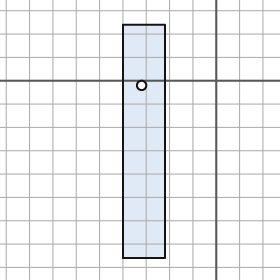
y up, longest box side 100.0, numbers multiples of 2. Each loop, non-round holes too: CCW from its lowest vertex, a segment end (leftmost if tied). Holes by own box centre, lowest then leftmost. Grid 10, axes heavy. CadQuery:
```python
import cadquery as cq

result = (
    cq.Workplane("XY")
    .moveTo(-40.0, -76.0)
    .lineTo(-22.0, -76.0)
    .lineTo(-22.0, 24.0)
    .lineTo(-40.0, 24.0)
    .close()
    .moveTo(-32.0, -2.0)
    .circle(2.0)
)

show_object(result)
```